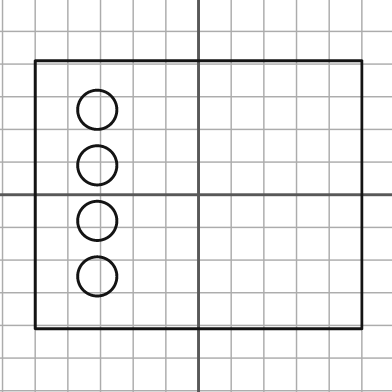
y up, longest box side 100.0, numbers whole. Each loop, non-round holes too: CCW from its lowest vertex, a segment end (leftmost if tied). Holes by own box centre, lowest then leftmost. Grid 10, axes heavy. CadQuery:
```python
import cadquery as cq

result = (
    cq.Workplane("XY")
    .moveTo(-50.0, -41.0)
    .lineTo(50.0, -41.0)
    .lineTo(50.0, 41.0)
    .lineTo(-50.0, 41.0)
    .close()
    .moveTo(-31.0, -25.0)
    .circle(6.0)
    .moveTo(-31.0, -8.0)
    .circle(6.0)
    .moveTo(-31.0, 9.0)
    .circle(6.0)
    .moveTo(-31.0, 26.0)
    .circle(6.0)
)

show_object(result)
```